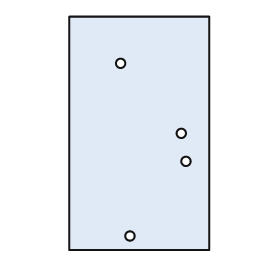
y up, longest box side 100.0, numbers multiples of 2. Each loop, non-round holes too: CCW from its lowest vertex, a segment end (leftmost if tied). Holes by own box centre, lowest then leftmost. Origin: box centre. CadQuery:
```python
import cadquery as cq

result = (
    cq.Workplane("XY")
    .moveTo(-30.0, -50.0)
    .lineTo(30.0, -50.0)
    .lineTo(30.0, 50.0)
    .lineTo(-30.0, 50.0)
    .close()
    .moveTo(-4.0, -44.0)
    .circle(2.0)
    .moveTo(20.0, -12.0)
    .circle(2.0)
    .moveTo(18.0, 0.0)
    .circle(2.0)
    .moveTo(-8.0, 30.0)
    .circle(2.0)
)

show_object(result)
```